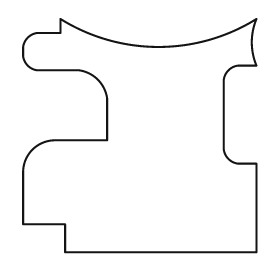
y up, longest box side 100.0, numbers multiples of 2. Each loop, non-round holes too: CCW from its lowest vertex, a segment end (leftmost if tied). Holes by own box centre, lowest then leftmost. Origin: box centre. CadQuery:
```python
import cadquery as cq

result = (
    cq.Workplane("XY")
    .moveTo(-32.0, -50.0)
    .lineTo(50.0, -50.0)
    .lineTo(50.0, -12.0)
    .lineTo(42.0, -12.0)
    .threePointArc((38.0, -10.0), (36.0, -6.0))
    .lineTo(36.0, 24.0)
    .threePointArc((38.0, 28.0), (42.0, 30.0))
    .lineTo(50.0, 30.0)
    .threePointArc((48.0, 40.0), (50.0, 50.0))
    .threePointArc((8.0, 38.0), (-34.0, 50.0))
    .lineTo(-34.0, 44.0)
    .lineTo(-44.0, 44.0)
    .threePointArc((-48.0, 42.0), (-50.0, 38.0))
    .lineTo(-50.0, 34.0)
    .threePointArc((-48.0, 30.0), (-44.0, 28.0))
    .lineTo(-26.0, 28.0)
    .threePointArc((-18.0, 24.0), (-14.0, 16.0))
    .lineTo(-14.0, -2.0)
    .lineTo(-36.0, -2.0)
    .threePointArc((-46.0, -6.0), (-50.0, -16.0))
    .lineTo(-50.0, -38.0)
    .lineTo(-32.0, -38.0)
    .close()
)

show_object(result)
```